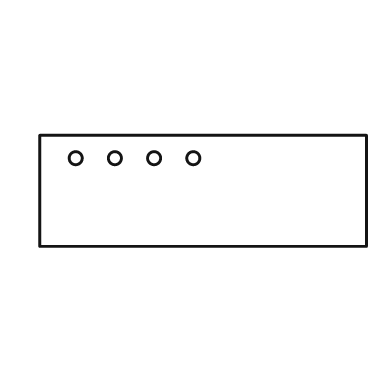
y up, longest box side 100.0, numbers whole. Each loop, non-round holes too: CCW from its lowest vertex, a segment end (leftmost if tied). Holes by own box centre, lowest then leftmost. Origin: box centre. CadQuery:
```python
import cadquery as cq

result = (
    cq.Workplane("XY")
    .moveTo(-50.0, -17.0)
    .lineTo(50.0, -17.0)
    .lineTo(50.0, 17.0)
    .lineTo(-50.0, 17.0)
    .close()
    .moveTo(-39.0, 10.0)
    .circle(2.0)
    .moveTo(-27.0, 10.0)
    .circle(2.0)
    .moveTo(-15.0, 10.0)
    .circle(2.0)
    .moveTo(-3.0, 10.0)
    .circle(2.0)
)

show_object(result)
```